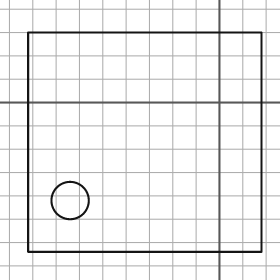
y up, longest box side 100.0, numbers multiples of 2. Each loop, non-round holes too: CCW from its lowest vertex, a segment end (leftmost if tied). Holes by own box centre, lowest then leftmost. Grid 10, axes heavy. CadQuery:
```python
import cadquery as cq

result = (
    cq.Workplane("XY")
    .moveTo(-82.0, -64.0)
    .lineTo(18.0, -64.0)
    .lineTo(18.0, 30.0)
    .lineTo(-82.0, 30.0)
    .close()
    .moveTo(-64.0, -42.0)
    .circle(8.0)
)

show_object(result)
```